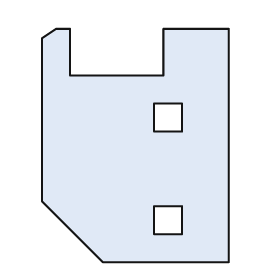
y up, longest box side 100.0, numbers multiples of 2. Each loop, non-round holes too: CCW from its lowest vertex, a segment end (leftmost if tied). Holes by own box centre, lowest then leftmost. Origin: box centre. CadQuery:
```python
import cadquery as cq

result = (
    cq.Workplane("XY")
    .moveTo(-14.0, -50.0)
    .lineTo(40.0, -50.0)
    .lineTo(40.0, 50.0)
    .lineTo(12.0, 50.0)
    .lineTo(12.0, 30.0)
    .lineTo(-28.0, 30.0)
    .lineTo(-28.0, 50.0)
    .lineTo(-34.0, 50.0)
    .lineTo(-40.0, 46.0)
    .lineTo(-40.0, -24.0)
    .close()
    .moveTo(8.0, -38.0)
    .lineTo(20.0, -38.0)
    .lineTo(20.0, -26.0)
    .lineTo(8.0, -26.0)
    .close()
    .moveTo(8.0, 6.0)
    .lineTo(20.0, 6.0)
    .lineTo(20.0, 18.0)
    .lineTo(8.0, 18.0)
    .close()
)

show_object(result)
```